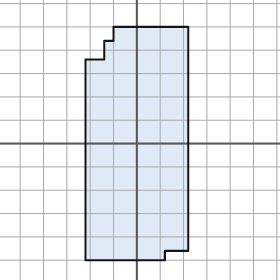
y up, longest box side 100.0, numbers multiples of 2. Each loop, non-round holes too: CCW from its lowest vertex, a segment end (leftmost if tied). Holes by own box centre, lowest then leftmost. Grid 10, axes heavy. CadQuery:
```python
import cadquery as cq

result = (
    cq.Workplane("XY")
    .moveTo(-22.0, -50.0)
    .lineTo(12.0, -50.0)
    .lineTo(12.0, -46.0)
    .lineTo(22.0, -46.0)
    .lineTo(22.0, 50.0)
    .lineTo(-10.0, 50.0)
    .lineTo(-10.0, 44.0)
    .lineTo(-14.0, 44.0)
    .lineTo(-14.0, 36.0)
    .lineTo(-22.0, 36.0)
    .close()
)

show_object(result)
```